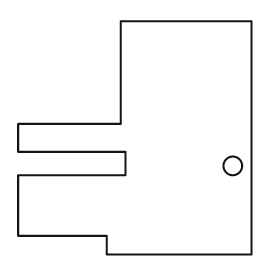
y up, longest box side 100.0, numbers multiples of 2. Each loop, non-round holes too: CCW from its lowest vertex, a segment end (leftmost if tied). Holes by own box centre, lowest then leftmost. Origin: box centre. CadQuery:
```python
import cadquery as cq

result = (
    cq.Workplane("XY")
    .moveTo(-12.0, -50.0)
    .lineTo(50.0, -50.0)
    .lineTo(50.0, 50.0)
    .lineTo(-6.0, 50.0)
    .lineTo(-6.0, 6.0)
    .lineTo(-50.0, 6.0)
    .lineTo(-50.0, -6.0)
    .lineTo(-4.0, -6.0)
    .lineTo(-4.0, -16.0)
    .lineTo(-50.0, -16.0)
    .lineTo(-50.0, -42.0)
    .lineTo(-12.0, -42.0)
    .close()
    .moveTo(42.0, -12.0)
    .circle(4.0)
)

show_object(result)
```